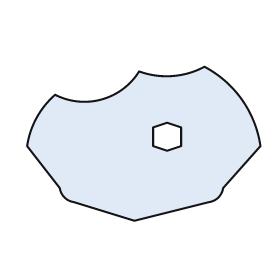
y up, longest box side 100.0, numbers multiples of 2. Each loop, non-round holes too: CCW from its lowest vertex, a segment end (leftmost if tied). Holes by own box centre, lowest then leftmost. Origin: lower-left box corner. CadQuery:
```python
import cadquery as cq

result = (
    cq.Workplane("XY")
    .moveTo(46.0, 0.0)
    .lineTo(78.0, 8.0)
    .threePointArc((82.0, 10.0), (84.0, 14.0))
    .lineTo(100.0, 32.0)
    .threePointArc((92.0, 52.0), (76.0, 66.0))
    .threePointArc((62.0, 62.0), (48.0, 64.0))
    .threePointArc((32.0, 52.0), (12.0, 54.0))
    .threePointArc((4.0, 44.0), (0.0, 32.0))
    .lineTo(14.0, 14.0)
    .threePointArc((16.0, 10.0), (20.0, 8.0))
    .close()
    .moveTo(60.0, 30.0)
    .lineTo(66.0, 32.0)
    .lineTo(66.0, 40.0)
    .lineTo(60.0, 42.0)
    .lineTo(54.0, 40.0)
    .lineTo(54.0, 32.0)
    .close()
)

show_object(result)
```